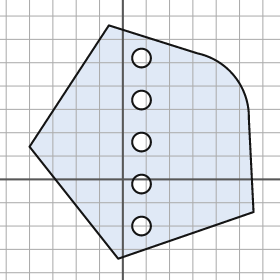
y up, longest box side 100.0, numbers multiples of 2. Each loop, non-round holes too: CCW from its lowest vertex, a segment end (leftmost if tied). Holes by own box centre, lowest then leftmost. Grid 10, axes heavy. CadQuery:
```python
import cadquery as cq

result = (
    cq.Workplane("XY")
    .moveTo(-2.0, -34.0)
    .lineTo(56.0, -14.0)
    .lineTo(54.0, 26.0)
    .threePointArc((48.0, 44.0), (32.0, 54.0))
    .lineTo(-6.0, 66.0)
    .lineTo(-40.0, 14.0)
    .close()
    .moveTo(8.0, -20.0)
    .circle(4.0)
    .moveTo(8.0, -2.0)
    .circle(4.0)
    .moveTo(8.0, 16.0)
    .circle(4.0)
    .moveTo(8.0, 34.0)
    .circle(4.0)
    .moveTo(8.0, 52.0)
    .circle(4.0)
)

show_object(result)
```